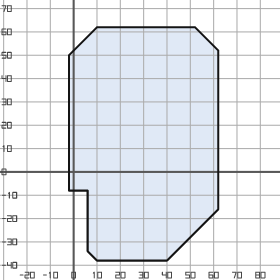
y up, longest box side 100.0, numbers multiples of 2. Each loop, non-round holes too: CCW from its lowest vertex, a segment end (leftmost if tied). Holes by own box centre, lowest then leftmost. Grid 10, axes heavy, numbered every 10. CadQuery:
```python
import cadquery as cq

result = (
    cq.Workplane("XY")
    .moveTo(10.0, -38.0)
    .lineTo(40.0, -38.0)
    .lineTo(62.0, -16.0)
    .lineTo(62.0, 52.0)
    .lineTo(52.0, 62.0)
    .lineTo(10.0, 62.0)
    .lineTo(-2.0, 50.0)
    .lineTo(-2.0, -8.0)
    .lineTo(6.0, -8.0)
    .lineTo(6.0, -34.0)
    .close()
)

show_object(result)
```